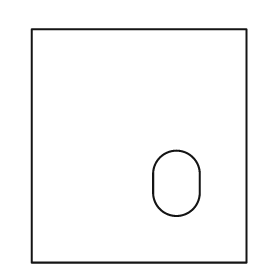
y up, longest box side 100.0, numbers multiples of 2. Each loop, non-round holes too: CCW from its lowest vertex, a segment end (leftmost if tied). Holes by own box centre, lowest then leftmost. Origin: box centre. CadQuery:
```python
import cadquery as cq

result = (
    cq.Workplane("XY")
    .moveTo(-46.0, -50.0)
    .lineTo(46.0, -50.0)
    .lineTo(46.0, 50.0)
    .lineTo(-46.0, 50.0)
    .close()
    .moveTo(6.0, -20.0)
    .threePointArc((16.0, -30.0), (26.0, -20.0))
    .lineTo(26.0, -12.0)
    .threePointArc((16.0, -2.0), (6.0, -12.0))
    .close()
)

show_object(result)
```